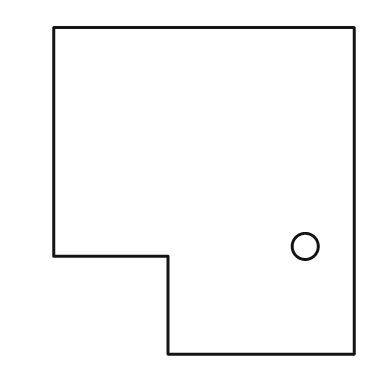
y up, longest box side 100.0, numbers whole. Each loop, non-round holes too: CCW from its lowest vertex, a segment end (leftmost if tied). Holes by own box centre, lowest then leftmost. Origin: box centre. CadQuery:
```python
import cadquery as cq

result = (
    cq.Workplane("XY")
    .moveTo(-11.0, -50.0)
    .lineTo(46.0, -50.0)
    .lineTo(46.0, 50.0)
    .lineTo(-46.0, 50.0)
    .lineTo(-46.0, -20.0)
    .lineTo(-11.0, -20.0)
    .close()
    .moveTo(31.0, -17.0)
    .circle(4.0)
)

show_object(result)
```